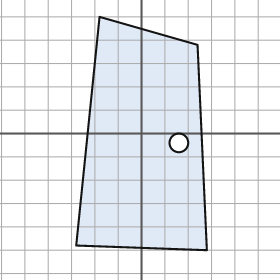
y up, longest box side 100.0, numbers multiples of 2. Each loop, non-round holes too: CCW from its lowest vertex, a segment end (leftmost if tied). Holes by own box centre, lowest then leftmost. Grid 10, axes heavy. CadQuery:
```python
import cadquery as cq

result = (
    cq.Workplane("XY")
    .moveTo(28.0, -50.0)
    .lineTo(24.0, 38.0)
    .lineTo(-18.0, 50.0)
    .lineTo(-28.0, -48.0)
    .close()
    .moveTo(16.0, -4.0)
    .circle(4.0)
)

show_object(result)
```